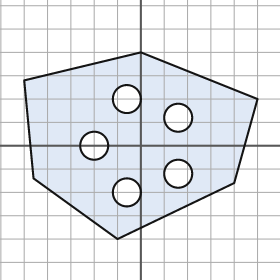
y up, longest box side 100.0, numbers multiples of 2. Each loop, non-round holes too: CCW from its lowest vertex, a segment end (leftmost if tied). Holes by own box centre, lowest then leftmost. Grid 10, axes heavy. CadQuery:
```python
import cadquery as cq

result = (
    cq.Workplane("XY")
    .moveTo(-10.0, -40.0)
    .lineTo(40.0, -16.0)
    .lineTo(50.0, 20.0)
    .lineTo(0.0, 40.0)
    .lineTo(-50.0, 28.0)
    .lineTo(-46.0, -14.0)
    .close()
    .moveTo(-6.0, -20.0)
    .circle(6.0)
    .moveTo(16.0, -12.0)
    .circle(6.0)
    .moveTo(-20.0, 0.0)
    .circle(6.0)
    .moveTo(16.0, 12.0)
    .circle(6.0)
    .moveTo(-6.0, 20.0)
    .circle(6.0)
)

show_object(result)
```